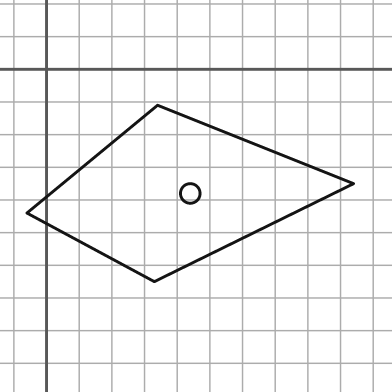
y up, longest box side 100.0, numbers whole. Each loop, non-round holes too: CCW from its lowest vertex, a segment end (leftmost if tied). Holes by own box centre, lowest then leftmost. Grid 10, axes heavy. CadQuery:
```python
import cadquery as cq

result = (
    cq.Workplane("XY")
    .moveTo(33.0, -65.0)
    .lineTo(94.0, -35.0)
    .lineTo(34.0, -11.0)
    .lineTo(-6.0, -44.0)
    .close()
    .moveTo(44.0, -38.0)
    .circle(3.0)
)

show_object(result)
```